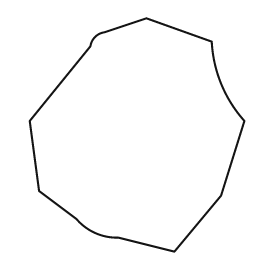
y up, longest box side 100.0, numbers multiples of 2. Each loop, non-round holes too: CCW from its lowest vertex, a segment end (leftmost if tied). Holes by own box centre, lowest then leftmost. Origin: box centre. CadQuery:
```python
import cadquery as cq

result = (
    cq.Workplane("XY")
    .moveTo(16.0, -50.0)
    .lineTo(36.0, -26.0)
    .lineTo(46.0, 6.0)
    .threePointArc((36.0, 22.0), (32.0, 40.0))
    .lineTo(4.0, 50.0)
    .lineTo(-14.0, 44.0)
    .threePointArc((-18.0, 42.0), (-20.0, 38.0))
    .lineTo(-46.0, 6.0)
    .lineTo(-42.0, -24.0)
    .lineTo(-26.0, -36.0)
    .threePointArc((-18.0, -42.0), (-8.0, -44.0))
    .close()
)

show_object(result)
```